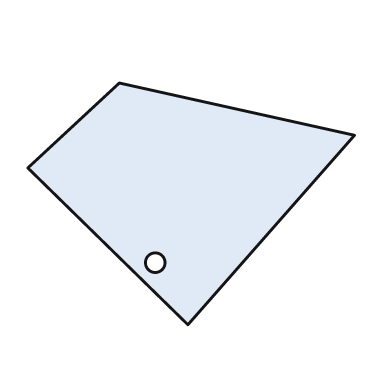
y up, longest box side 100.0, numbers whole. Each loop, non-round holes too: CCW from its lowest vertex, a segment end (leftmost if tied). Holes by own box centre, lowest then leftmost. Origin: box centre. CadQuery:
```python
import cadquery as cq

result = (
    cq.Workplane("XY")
    .moveTo(-1.0, -37.0)
    .lineTo(50.0, 21.0)
    .lineTo(-22.0, 37.0)
    .lineTo(-50.0, 11.0)
    .close()
    .moveTo(-11.0, -18.0)
    .circle(3.0)
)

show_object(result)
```